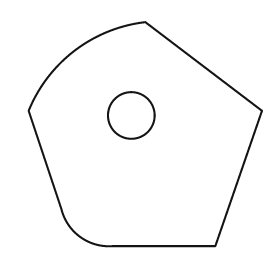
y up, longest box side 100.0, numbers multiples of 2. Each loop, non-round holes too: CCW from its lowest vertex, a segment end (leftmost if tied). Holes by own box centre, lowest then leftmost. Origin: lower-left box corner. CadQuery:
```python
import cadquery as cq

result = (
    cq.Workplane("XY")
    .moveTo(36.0, 0.0)
    .lineTo(80.0, 0.0)
    .lineTo(100.0, 58.0)
    .lineTo(50.0, 96.0)
    .threePointArc((20.0, 84.0), (0.0, 58.0))
    .lineTo(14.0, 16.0)
    .threePointArc((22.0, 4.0), (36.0, 0.0))
    .close()
    .moveTo(44.0, 56.0)
    .circle(10.0)
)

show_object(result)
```